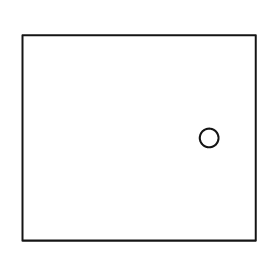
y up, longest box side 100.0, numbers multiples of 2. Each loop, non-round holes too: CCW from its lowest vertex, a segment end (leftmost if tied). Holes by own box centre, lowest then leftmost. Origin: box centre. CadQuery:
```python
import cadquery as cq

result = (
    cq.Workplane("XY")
    .moveTo(-50.0, -44.0)
    .lineTo(50.0, -44.0)
    .lineTo(50.0, 44.0)
    .lineTo(-50.0, 44.0)
    .close()
    .moveTo(30.0, 0.0)
    .circle(4.0)
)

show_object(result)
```